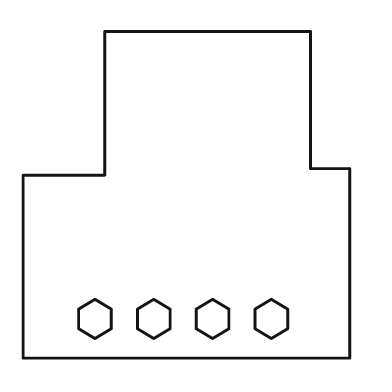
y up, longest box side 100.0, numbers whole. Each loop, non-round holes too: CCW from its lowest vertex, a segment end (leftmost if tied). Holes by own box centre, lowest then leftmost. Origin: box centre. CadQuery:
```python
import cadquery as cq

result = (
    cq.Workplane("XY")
    .moveTo(-50.0, -50.0)
    .lineTo(50.0, -50.0)
    .lineTo(50.0, 8.0)
    .lineTo(38.0, 8.0)
    .lineTo(38.0, 50.0)
    .lineTo(-25.0, 50.0)
    .lineTo(-25.0, 6.0)
    .lineTo(-50.0, 6.0)
    .close()
    .moveTo(-28.0, -44.0)
    .lineTo(-23.0, -41.0)
    .lineTo(-23.0, -35.0)
    .lineTo(-28.0, -32.0)
    .lineTo(-33.0, -35.0)
    .lineTo(-33.0, -41.0)
    .close()
    .moveTo(-10.0, -44.0)
    .lineTo(-5.0, -41.0)
    .lineTo(-5.0, -35.0)
    .lineTo(-10.0, -32.0)
    .lineTo(-15.0, -35.0)
    .lineTo(-15.0, -41.0)
    .close()
    .moveTo(8.0, -44.0)
    .lineTo(13.0, -41.0)
    .lineTo(13.0, -35.0)
    .lineTo(8.0, -32.0)
    .lineTo(3.0, -35.0)
    .lineTo(3.0, -41.0)
    .close()
    .moveTo(26.0, -44.0)
    .lineTo(31.0, -41.0)
    .lineTo(31.0, -35.0)
    .lineTo(26.0, -32.0)
    .lineTo(21.0, -35.0)
    .lineTo(21.0, -41.0)
    .close()
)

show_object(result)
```